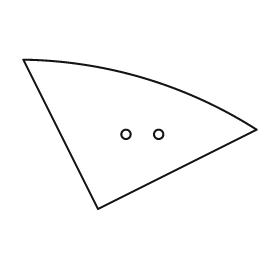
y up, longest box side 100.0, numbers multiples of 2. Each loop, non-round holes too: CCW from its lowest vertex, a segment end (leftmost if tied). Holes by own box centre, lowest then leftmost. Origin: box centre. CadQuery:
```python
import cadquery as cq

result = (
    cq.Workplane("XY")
    .moveTo(-18.0, -32.0)
    .lineTo(50.0, 2.0)
    .threePointArc((2.0, 24.0), (-50.0, 32.0))
    .close()
    .moveTo(-6.0, 0.0)
    .circle(2.0)
    .moveTo(8.0, 0.0)
    .circle(2.0)
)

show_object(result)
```